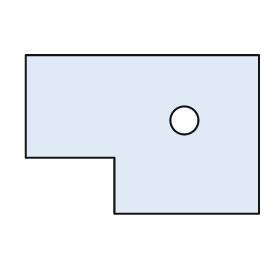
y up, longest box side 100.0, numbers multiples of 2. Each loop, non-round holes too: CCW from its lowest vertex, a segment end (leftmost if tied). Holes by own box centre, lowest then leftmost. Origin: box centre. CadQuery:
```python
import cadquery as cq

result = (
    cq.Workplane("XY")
    .moveTo(-12.0, -34.0)
    .lineTo(50.0, -34.0)
    .lineTo(50.0, 34.0)
    .lineTo(-50.0, 34.0)
    .lineTo(-50.0, -10.0)
    .lineTo(-12.0, -10.0)
    .close()
    .moveTo(18.0, 6.0)
    .circle(6.0)
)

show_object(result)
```